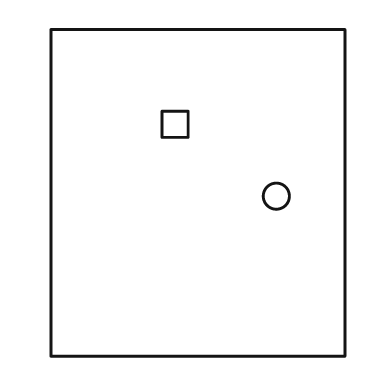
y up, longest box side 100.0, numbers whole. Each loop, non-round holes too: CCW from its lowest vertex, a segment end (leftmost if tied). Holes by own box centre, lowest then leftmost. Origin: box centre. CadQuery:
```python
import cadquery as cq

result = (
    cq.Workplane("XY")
    .moveTo(-45.0, -50.0)
    .lineTo(45.0, -50.0)
    .lineTo(45.0, 50.0)
    .lineTo(-45.0, 50.0)
    .close()
    .moveTo(24.0, -1.0)
    .circle(4.0)
    .moveTo(-11.0, 17.0)
    .lineTo(-3.0, 17.0)
    .lineTo(-3.0, 25.0)
    .lineTo(-11.0, 25.0)
    .close()
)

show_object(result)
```